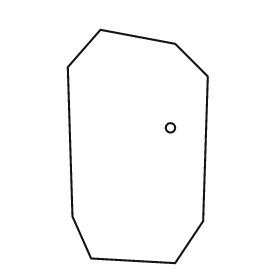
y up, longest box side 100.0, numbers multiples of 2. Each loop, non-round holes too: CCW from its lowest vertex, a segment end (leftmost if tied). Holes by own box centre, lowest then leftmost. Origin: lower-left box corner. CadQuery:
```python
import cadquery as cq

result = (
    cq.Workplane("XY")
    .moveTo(46.0, 0.0)
    .lineTo(58.0, 18.0)
    .lineTo(60.0, 80.0)
    .lineTo(46.0, 94.0)
    .lineTo(14.0, 100.0)
    .lineTo(0.0, 84.0)
    .lineTo(2.0, 20.0)
    .lineTo(10.0, 2.0)
    .close()
    .moveTo(44.0, 58.0)
    .circle(2.0)
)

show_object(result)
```